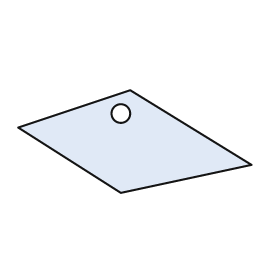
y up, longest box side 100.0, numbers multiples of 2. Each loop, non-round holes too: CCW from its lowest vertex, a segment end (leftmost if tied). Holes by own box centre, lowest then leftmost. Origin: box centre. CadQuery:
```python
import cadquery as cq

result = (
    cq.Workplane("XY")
    .moveTo(-6.0, -22.0)
    .lineTo(50.0, -10.0)
    .lineTo(-2.0, 22.0)
    .lineTo(-50.0, 6.0)
    .close()
    .moveTo(-6.0, 12.0)
    .circle(4.0)
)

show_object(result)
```